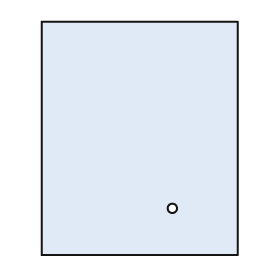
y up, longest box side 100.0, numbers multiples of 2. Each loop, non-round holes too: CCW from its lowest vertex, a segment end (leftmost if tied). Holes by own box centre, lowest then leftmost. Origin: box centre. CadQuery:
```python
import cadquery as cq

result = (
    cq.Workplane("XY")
    .moveTo(-42.0, -50.0)
    .lineTo(42.0, -50.0)
    .lineTo(42.0, 50.0)
    .lineTo(-42.0, 50.0)
    .close()
    .moveTo(14.0, -30.0)
    .circle(2.0)
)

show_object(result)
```